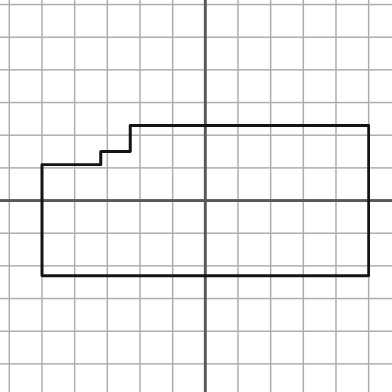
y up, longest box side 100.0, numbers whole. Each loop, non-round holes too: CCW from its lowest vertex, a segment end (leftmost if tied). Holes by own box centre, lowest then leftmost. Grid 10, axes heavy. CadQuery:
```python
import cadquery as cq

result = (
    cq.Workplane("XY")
    .moveTo(-50.0, -23.0)
    .lineTo(50.0, -23.0)
    .lineTo(50.0, 23.0)
    .lineTo(-23.0, 23.0)
    .lineTo(-23.0, 15.0)
    .lineTo(-32.0, 15.0)
    .lineTo(-32.0, 11.0)
    .lineTo(-50.0, 11.0)
    .close()
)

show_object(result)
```